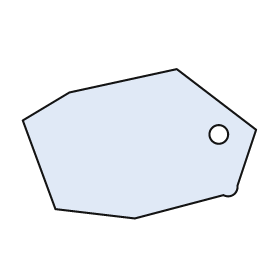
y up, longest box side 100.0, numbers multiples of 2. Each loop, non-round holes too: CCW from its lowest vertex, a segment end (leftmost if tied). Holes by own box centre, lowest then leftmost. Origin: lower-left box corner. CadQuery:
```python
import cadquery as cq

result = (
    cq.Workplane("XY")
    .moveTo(48.0, 0.0)
    .lineTo(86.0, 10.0)
    .threePointArc((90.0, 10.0), (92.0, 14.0))
    .lineTo(100.0, 38.0)
    .lineTo(66.0, 64.0)
    .lineTo(20.0, 54.0)
    .lineTo(0.0, 42.0)
    .lineTo(14.0, 4.0)
    .close()
    .moveTo(84.0, 36.0)
    .circle(4.0)
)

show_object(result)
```